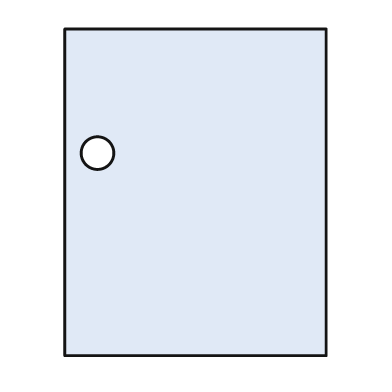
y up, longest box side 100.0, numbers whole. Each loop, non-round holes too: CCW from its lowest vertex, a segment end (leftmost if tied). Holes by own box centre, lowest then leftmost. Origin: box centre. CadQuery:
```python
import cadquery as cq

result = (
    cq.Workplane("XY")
    .moveTo(-40.0, -50.0)
    .lineTo(40.0, -50.0)
    .lineTo(40.0, 50.0)
    .lineTo(-40.0, 50.0)
    .close()
    .moveTo(-30.0, 12.0)
    .circle(5.0)
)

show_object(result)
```